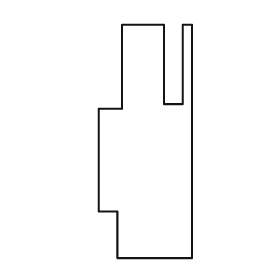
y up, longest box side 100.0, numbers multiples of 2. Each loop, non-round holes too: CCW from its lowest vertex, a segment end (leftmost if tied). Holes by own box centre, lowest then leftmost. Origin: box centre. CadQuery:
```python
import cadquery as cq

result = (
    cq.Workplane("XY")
    .moveTo(-12.0, -50.0)
    .lineTo(20.0, -50.0)
    .lineTo(20.0, 50.0)
    .lineTo(16.0, 50.0)
    .lineTo(16.0, 16.0)
    .lineTo(8.0, 16.0)
    .lineTo(8.0, 50.0)
    .lineTo(-10.0, 50.0)
    .lineTo(-10.0, 14.0)
    .lineTo(-20.0, 14.0)
    .lineTo(-20.0, -30.0)
    .lineTo(-12.0, -30.0)
    .close()
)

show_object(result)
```